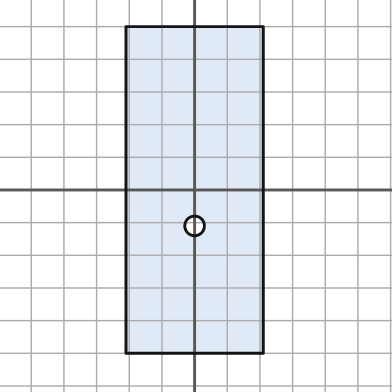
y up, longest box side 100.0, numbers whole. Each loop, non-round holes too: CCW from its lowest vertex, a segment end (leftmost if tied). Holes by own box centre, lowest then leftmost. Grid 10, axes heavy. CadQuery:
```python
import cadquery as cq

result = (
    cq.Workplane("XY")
    .moveTo(-21.0, -50.0)
    .lineTo(21.0, -50.0)
    .lineTo(21.0, 50.0)
    .lineTo(-21.0, 50.0)
    .close()
    .moveTo(0.0, -11.0)
    .circle(3.0)
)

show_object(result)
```